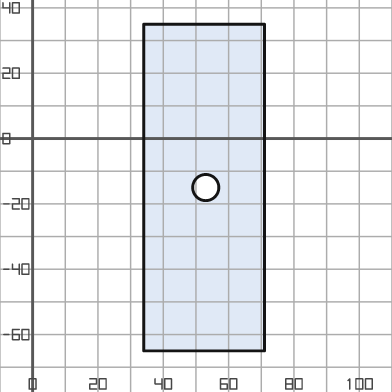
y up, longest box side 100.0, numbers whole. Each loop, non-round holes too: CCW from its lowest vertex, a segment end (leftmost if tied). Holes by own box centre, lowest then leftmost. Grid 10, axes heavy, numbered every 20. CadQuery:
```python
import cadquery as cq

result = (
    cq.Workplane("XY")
    .moveTo(34.0, -65.0)
    .lineTo(71.0, -65.0)
    .lineTo(71.0, 35.0)
    .lineTo(34.0, 35.0)
    .close()
    .moveTo(53.0, -15.0)
    .circle(4.0)
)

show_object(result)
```